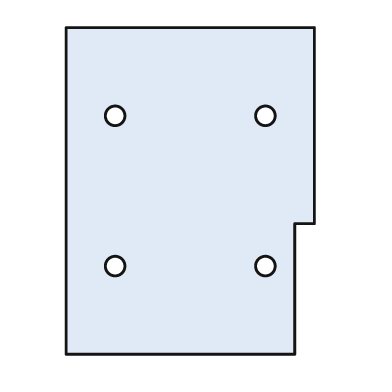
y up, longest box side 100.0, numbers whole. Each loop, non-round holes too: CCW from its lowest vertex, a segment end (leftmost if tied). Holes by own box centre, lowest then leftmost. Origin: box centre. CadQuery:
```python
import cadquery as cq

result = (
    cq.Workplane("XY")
    .moveTo(-38.0, -50.0)
    .lineTo(32.0, -50.0)
    .lineTo(32.0, -10.0)
    .lineTo(38.0, -10.0)
    .lineTo(38.0, 50.0)
    .lineTo(-38.0, 50.0)
    .close()
    .moveTo(-23.0, -23.0)
    .circle(3.0)
    .moveTo(23.0, -23.0)
    .circle(3.0)
    .moveTo(-23.0, 23.0)
    .circle(3.0)
    .moveTo(23.0, 23.0)
    .circle(3.0)
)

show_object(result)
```